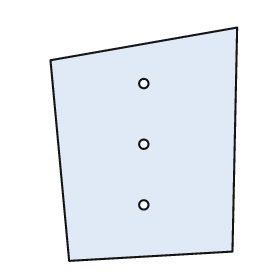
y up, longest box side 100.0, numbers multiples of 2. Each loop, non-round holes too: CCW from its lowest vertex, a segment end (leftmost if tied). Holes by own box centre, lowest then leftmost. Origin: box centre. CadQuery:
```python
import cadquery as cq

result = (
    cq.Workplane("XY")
    .moveTo(-32.0, -50.0)
    .lineTo(38.0, -46.0)
    .lineTo(40.0, 50.0)
    .lineTo(-40.0, 36.0)
    .close()
    .moveTo(0.0, -26.0)
    .circle(2.0)
    .moveTo(0.0, 0.0)
    .circle(2.0)
    .moveTo(0.0, 26.0)
    .circle(2.0)
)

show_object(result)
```